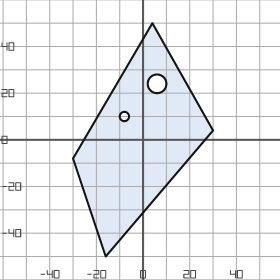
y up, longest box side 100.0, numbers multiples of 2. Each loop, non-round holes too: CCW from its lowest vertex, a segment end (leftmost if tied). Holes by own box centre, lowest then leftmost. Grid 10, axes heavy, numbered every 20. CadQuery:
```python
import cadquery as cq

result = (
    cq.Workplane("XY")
    .moveTo(-16.0, -50.0)
    .lineTo(30.0, 4.0)
    .lineTo(4.0, 50.0)
    .lineTo(-30.0, -8.0)
    .close()
    .moveTo(-8.0, 10.0)
    .circle(2.0)
    .moveTo(6.0, 24.0)
    .circle(4.0)
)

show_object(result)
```